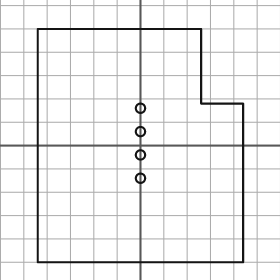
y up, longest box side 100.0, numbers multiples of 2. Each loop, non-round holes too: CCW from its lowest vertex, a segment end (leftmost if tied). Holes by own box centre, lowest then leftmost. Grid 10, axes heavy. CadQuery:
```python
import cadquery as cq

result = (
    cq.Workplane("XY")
    .moveTo(-44.0, -50.0)
    .lineTo(44.0, -50.0)
    .lineTo(44.0, 18.0)
    .lineTo(26.0, 18.0)
    .lineTo(26.0, 50.0)
    .lineTo(-44.0, 50.0)
    .close()
    .moveTo(0.0, -14.0)
    .circle(2.0)
    .moveTo(0.0, -4.0)
    .circle(2.0)
    .moveTo(0.0, 6.0)
    .circle(2.0)
    .moveTo(0.0, 16.0)
    .circle(2.0)
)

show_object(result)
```